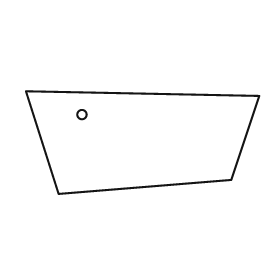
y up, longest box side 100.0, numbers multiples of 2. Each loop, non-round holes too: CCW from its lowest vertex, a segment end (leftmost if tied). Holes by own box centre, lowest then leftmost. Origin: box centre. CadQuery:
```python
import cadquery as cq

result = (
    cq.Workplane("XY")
    .moveTo(-36.0, -22.0)
    .lineTo(38.0, -16.0)
    .lineTo(50.0, 20.0)
    .lineTo(-50.0, 22.0)
    .close()
    .moveTo(-26.0, 12.0)
    .circle(2.0)
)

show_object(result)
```